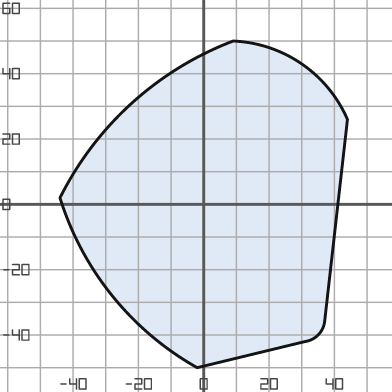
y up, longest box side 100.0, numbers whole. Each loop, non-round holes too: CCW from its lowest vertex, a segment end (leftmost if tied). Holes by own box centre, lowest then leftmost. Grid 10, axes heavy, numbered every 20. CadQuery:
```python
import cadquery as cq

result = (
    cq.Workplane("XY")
    .moveTo(-2.0, -50.0)
    .lineTo(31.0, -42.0)
    .threePointArc((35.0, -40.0), (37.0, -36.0))
    .lineTo(44.0, 26.0)
    .threePointArc((30.0, 43.0), (9.0, 50.0))
    .threePointArc((-22.0, 31.0), (-44.0, 2.0))
    .threePointArc((-28.0, -28.0), (-2.0, -50.0))
    .close()
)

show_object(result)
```